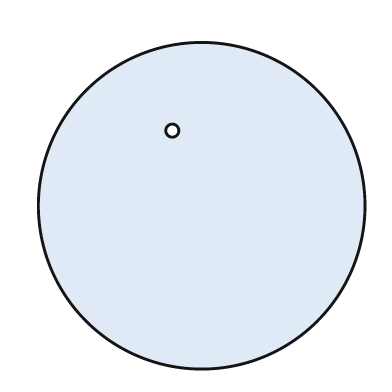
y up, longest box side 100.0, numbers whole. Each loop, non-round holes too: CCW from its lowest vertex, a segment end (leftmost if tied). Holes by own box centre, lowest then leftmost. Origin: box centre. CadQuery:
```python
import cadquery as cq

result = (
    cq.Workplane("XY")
    .moveTo(0.0, 0.0)
    .circle(50.0)
    .moveTo(-9.0, 23.0)
    .circle(2.0)
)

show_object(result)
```